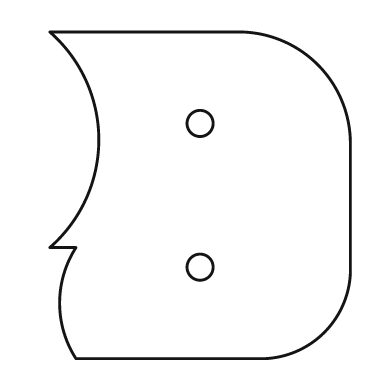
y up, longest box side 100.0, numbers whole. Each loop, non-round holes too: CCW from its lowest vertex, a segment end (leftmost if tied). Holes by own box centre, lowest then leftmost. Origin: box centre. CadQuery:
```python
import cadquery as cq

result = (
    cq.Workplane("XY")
    .moveTo(-38.0, -50.0)
    .lineTo(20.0, -50.0)
    .threePointArc((38.0, -42.0), (46.0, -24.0))
    .lineTo(46.0, 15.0)
    .threePointArc((36.0, 40.0), (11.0, 50.0))
    .lineTo(-46.0, 50.0)
    .threePointArc((-31.0, 17.0), (-46.0, -16.0))
    .lineTo(-38.0, -16.0)
    .threePointArc((-43.0, -33.0), (-38.0, -50.0))
    .close()
    .moveTo(0.0, -22.0)
    .circle(4.0)
    .moveTo(0.0, 22.0)
    .circle(4.0)
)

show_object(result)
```